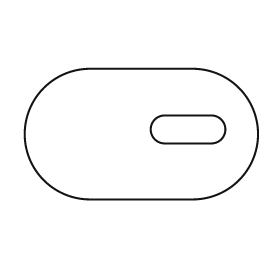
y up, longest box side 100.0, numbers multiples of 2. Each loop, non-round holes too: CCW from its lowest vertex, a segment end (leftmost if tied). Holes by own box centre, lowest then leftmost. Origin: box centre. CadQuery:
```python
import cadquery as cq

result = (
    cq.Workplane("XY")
    .moveTo(-22.0, -28.0)
    .lineTo(22.0, -28.0)
    .threePointArc((50.0, 0.0), (22.0, 28.0))
    .lineTo(-22.0, 28.0)
    .threePointArc((-50.0, 0.0), (-22.0, -28.0))
    .close()
    .moveTo(10.0, -4.0)
    .lineTo(30.0, -4.0)
    .threePointArc((36.0, 2.0), (30.0, 8.0))
    .lineTo(10.0, 8.0)
    .threePointArc((4.0, 2.0), (10.0, -4.0))
    .close()
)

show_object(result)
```